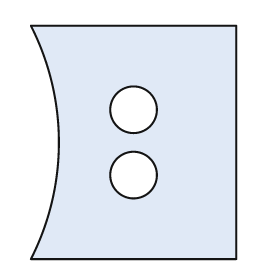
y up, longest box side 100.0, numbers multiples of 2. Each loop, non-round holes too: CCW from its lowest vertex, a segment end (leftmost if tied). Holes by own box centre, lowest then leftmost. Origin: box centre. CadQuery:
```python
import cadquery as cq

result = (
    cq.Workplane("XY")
    .moveTo(-44.0, -50.0)
    .lineTo(44.0, -50.0)
    .lineTo(44.0, 50.0)
    .lineTo(-44.0, 50.0)
    .threePointArc((-32.0, 0.0), (-44.0, -50.0))
    .close()
    .moveTo(0.0, -14.0)
    .circle(10.0)
    .moveTo(0.0, 14.0)
    .circle(10.0)
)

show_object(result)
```